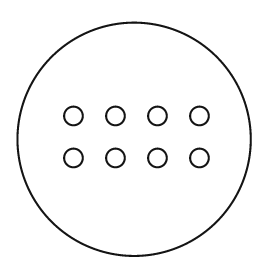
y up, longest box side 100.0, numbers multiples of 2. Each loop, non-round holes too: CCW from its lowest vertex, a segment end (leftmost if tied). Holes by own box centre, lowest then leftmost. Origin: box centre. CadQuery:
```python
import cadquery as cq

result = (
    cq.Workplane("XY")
    .moveTo(0.0, 0.0)
    .circle(50.0)
    .moveTo(-26.0, -8.0)
    .circle(4.0)
    .moveTo(-8.0, -8.0)
    .circle(4.0)
    .moveTo(10.0, -8.0)
    .circle(4.0)
    .moveTo(28.0, -8.0)
    .circle(4.0)
    .moveTo(-26.0, 10.0)
    .circle(4.0)
    .moveTo(-8.0, 10.0)
    .circle(4.0)
    .moveTo(10.0, 10.0)
    .circle(4.0)
    .moveTo(28.0, 10.0)
    .circle(4.0)
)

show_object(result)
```